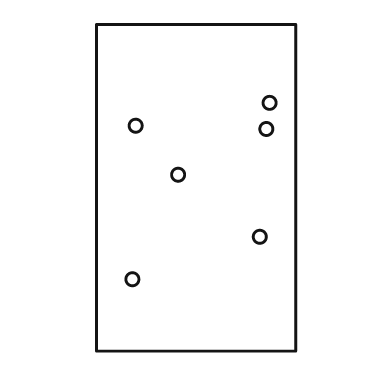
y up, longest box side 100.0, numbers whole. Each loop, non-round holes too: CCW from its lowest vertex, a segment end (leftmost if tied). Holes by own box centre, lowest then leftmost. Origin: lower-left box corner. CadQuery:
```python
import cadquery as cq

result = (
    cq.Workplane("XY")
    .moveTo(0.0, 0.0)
    .lineTo(61.0, 0.0)
    .lineTo(61.0, 100.0)
    .lineTo(0.0, 100.0)
    .close()
    .moveTo(11.0, 22.0)
    .circle(2.0)
    .moveTo(50.0, 35.0)
    .circle(2.0)
    .moveTo(25.0, 54.0)
    .circle(2.0)
    .moveTo(52.0, 68.0)
    .circle(2.0)
    .moveTo(12.0, 69.0)
    .circle(2.0)
    .moveTo(53.0, 76.0)
    .circle(2.0)
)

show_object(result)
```